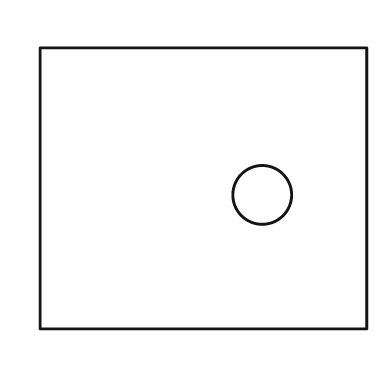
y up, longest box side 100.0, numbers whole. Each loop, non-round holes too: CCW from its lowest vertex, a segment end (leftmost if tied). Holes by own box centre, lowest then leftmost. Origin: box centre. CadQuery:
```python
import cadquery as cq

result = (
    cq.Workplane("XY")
    .moveTo(-50.0, -43.0)
    .lineTo(50.0, -43.0)
    .lineTo(50.0, 43.0)
    .lineTo(-50.0, 43.0)
    .close()
    .moveTo(18.0, -2.0)
    .circle(9.0)
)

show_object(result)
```